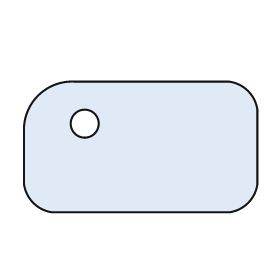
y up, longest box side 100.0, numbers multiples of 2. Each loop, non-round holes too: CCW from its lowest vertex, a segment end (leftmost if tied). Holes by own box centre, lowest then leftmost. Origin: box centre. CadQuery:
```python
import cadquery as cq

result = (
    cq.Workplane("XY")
    .moveTo(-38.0, -28.0)
    .lineTo(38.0, -28.0)
    .threePointArc((46.0, -24.0), (50.0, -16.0))
    .lineTo(50.0, 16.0)
    .threePointArc((46.0, 24.0), (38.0, 28.0))
    .lineTo(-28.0, 28.0)
    .threePointArc((-44.0, 22.0), (-50.0, 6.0))
    .lineTo(-50.0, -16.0)
    .threePointArc((-46.0, -24.0), (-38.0, -28.0))
    .close()
    .moveTo(-24.0, 10.0)
    .circle(6.0)
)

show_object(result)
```